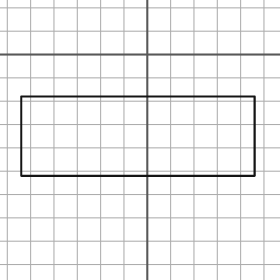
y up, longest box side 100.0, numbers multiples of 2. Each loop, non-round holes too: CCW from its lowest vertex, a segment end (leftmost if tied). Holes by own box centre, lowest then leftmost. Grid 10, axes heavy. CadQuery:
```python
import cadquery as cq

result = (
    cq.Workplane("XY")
    .moveTo(-54.0, -52.0)
    .lineTo(46.0, -52.0)
    .lineTo(46.0, -18.0)
    .lineTo(-54.0, -18.0)
    .close()
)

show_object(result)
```